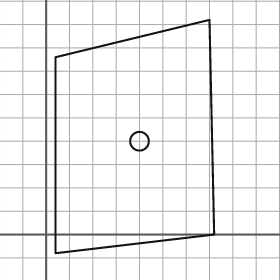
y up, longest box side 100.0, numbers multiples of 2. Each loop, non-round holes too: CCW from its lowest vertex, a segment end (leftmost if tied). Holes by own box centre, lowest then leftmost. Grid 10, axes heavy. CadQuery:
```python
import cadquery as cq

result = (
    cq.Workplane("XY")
    .moveTo(4.0, -8.0)
    .lineTo(72.0, 0.0)
    .lineTo(70.0, 92.0)
    .lineTo(4.0, 76.0)
    .close()
    .moveTo(40.0, 40.0)
    .circle(4.0)
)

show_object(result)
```